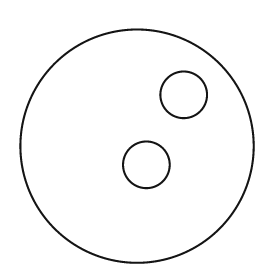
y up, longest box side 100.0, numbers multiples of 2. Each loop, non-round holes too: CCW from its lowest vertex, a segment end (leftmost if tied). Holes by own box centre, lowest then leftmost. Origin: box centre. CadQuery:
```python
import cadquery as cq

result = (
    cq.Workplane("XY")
    .moveTo(0.0, 0.0)
    .circle(50.0)
    .moveTo(4.0, -8.0)
    .circle(10.0)
    .moveTo(20.0, 22.0)
    .circle(10.0)
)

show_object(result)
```